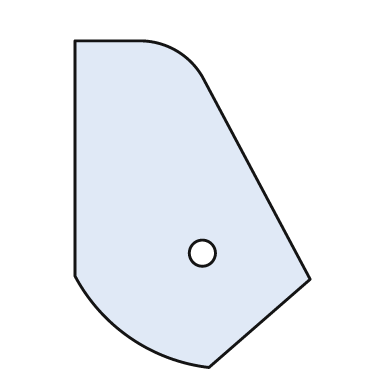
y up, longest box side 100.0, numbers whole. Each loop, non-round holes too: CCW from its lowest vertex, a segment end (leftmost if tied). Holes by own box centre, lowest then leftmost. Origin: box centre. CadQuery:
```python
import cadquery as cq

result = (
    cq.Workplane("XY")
    .moveTo(5.0, -50.0)
    .lineTo(36.0, -23.0)
    .lineTo(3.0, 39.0)
    .threePointArc((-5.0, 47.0), (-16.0, 50.0))
    .lineTo(-36.0, 50.0)
    .lineTo(-36.0, -22.0)
    .threePointArc((-19.0, -41.0), (5.0, -50.0))
    .close()
    .moveTo(3.0, -15.0)
    .circle(4.0)
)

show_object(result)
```